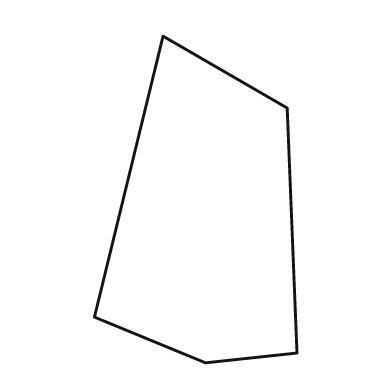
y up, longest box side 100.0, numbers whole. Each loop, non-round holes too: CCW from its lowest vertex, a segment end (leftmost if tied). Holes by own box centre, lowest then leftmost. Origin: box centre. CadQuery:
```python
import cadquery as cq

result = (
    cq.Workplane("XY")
    .moveTo(3.0, -50.0)
    .lineTo(31.0, -47.0)
    .lineTo(28.0, 28.0)
    .lineTo(-10.0, 50.0)
    .lineTo(-31.0, -36.0)
    .close()
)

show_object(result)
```